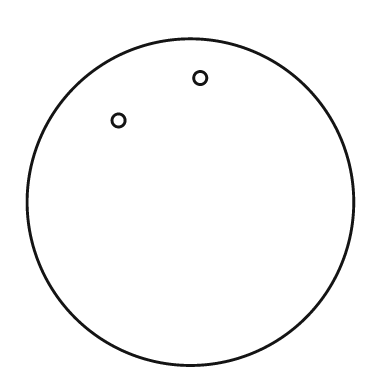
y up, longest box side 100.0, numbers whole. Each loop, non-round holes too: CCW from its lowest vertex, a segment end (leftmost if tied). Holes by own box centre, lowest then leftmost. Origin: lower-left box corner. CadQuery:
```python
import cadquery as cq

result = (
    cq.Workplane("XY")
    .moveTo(50.0, 50.0)
    .circle(50.0)
    .moveTo(28.0, 75.0)
    .circle(2.0)
    .moveTo(53.0, 88.0)
    .circle(2.0)
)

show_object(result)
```